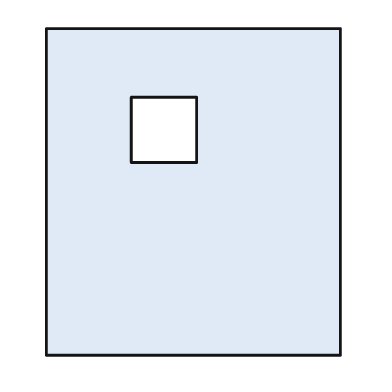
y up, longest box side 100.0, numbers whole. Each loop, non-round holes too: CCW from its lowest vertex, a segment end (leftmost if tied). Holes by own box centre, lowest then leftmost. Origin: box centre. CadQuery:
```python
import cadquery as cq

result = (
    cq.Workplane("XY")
    .moveTo(-45.0, -50.0)
    .lineTo(45.0, -50.0)
    .lineTo(45.0, 50.0)
    .lineTo(-45.0, 50.0)
    .close()
    .moveTo(-19.0, 9.0)
    .lineTo(1.0, 9.0)
    .lineTo(1.0, 29.0)
    .lineTo(-19.0, 29.0)
    .close()
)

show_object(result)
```